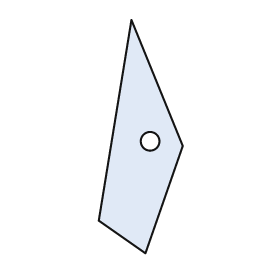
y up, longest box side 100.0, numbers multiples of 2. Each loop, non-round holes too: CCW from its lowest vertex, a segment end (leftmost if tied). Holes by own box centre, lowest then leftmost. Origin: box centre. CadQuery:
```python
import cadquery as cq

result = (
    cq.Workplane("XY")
    .moveTo(2.0, -50.0)
    .lineTo(18.0, -4.0)
    .lineTo(-4.0, 50.0)
    .lineTo(-18.0, -36.0)
    .close()
    .moveTo(4.0, -2.0)
    .circle(4.0)
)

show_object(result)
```